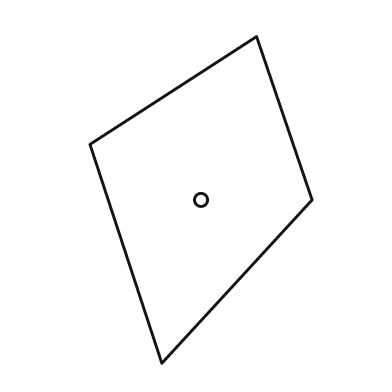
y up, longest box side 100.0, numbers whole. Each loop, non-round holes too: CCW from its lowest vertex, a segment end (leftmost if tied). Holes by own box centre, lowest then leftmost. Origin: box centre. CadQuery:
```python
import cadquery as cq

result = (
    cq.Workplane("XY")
    .moveTo(-12.0, -50.0)
    .lineTo(34.0, 0.0)
    .lineTo(17.0, 50.0)
    .lineTo(-34.0, 17.0)
    .close()
    .moveTo(0.0, 0.0)
    .circle(2.0)
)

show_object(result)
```